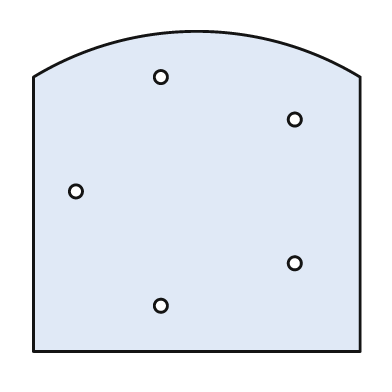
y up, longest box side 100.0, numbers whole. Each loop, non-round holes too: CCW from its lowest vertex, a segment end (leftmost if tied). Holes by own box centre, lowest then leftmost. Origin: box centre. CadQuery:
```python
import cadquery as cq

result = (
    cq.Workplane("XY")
    .moveTo(-50.0, -49.0)
    .lineTo(50.0, -49.0)
    .lineTo(50.0, 35.0)
    .threePointArc((0.0, 49.0), (-50.0, 35.0))
    .close()
    .moveTo(-11.0, -35.0)
    .circle(2.0)
    .moveTo(30.0, -22.0)
    .circle(2.0)
    .moveTo(-37.0, 0.0)
    .circle(2.0)
    .moveTo(30.0, 22.0)
    .circle(2.0)
    .moveTo(-11.0, 35.0)
    .circle(2.0)
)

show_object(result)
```